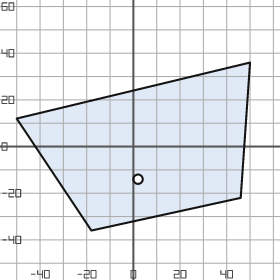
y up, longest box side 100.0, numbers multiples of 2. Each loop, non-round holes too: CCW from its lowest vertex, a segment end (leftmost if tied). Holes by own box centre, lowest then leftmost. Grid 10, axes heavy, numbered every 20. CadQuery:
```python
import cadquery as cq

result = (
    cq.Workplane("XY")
    .moveTo(-18.0, -36.0)
    .lineTo(46.0, -22.0)
    .lineTo(50.0, 36.0)
    .lineTo(-50.0, 12.0)
    .close()
    .moveTo(2.0, -14.0)
    .circle(2.0)
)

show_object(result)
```